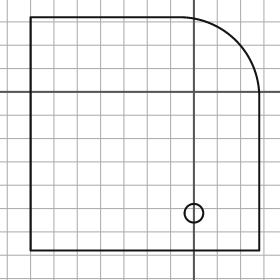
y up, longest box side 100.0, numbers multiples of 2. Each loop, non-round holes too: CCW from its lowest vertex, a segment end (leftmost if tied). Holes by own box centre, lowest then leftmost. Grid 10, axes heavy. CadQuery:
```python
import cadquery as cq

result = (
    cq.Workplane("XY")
    .moveTo(-70.0, -68.0)
    .lineTo(28.0, -68.0)
    .lineTo(28.0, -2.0)
    .threePointArc((18.0, 22.0), (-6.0, 32.0))
    .lineTo(-70.0, 32.0)
    .close()
    .moveTo(0.0, -52.0)
    .circle(4.0)
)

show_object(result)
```